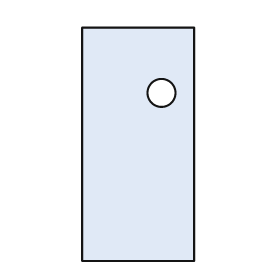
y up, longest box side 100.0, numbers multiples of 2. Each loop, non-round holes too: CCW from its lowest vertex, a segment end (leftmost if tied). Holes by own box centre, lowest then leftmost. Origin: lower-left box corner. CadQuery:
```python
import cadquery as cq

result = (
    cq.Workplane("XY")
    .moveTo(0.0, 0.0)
    .lineTo(48.0, 0.0)
    .lineTo(48.0, 100.0)
    .lineTo(0.0, 100.0)
    .close()
    .moveTo(34.0, 72.0)
    .circle(6.0)
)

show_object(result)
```